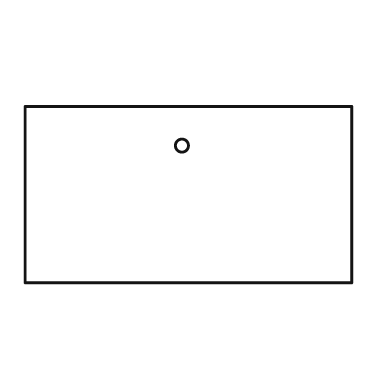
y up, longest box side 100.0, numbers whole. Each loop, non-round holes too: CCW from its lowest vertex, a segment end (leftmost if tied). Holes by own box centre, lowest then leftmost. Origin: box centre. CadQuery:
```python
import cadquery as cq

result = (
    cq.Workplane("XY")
    .moveTo(-50.0, -27.0)
    .lineTo(50.0, -27.0)
    .lineTo(50.0, 27.0)
    .lineTo(-50.0, 27.0)
    .close()
    .moveTo(-2.0, 15.0)
    .circle(2.0)
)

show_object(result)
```